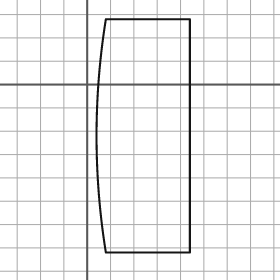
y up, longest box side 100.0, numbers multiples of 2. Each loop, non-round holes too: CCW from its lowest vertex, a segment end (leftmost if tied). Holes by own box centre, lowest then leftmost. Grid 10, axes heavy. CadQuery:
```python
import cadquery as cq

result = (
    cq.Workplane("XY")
    .moveTo(8.0, -72.0)
    .lineTo(44.0, -72.0)
    .lineTo(44.0, 28.0)
    .lineTo(8.0, 28.0)
    .threePointArc((4.0, -22.0), (8.0, -72.0))
    .close()
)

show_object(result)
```